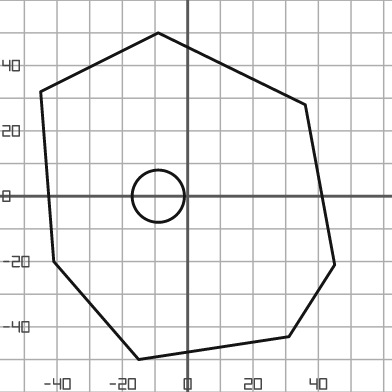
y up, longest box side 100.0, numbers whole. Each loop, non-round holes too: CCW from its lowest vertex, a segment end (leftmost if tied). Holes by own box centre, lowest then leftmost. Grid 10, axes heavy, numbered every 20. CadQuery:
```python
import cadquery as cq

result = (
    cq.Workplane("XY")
    .moveTo(-15.0, -50.0)
    .lineTo(31.0, -43.0)
    .lineTo(45.0, -21.0)
    .lineTo(36.0, 28.0)
    .lineTo(-9.0, 50.0)
    .lineTo(-45.0, 32.0)
    .lineTo(-41.0, -20.0)
    .close()
    .moveTo(-9.0, 0.0)
    .circle(8.0)
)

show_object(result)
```